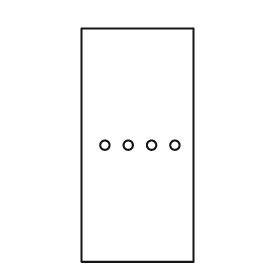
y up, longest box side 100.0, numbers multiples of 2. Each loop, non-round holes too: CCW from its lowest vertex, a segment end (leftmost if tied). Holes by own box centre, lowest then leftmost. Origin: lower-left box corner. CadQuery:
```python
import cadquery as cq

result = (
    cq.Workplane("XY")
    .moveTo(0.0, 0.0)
    .lineTo(48.0, 0.0)
    .lineTo(48.0, 100.0)
    .lineTo(0.0, 100.0)
    .close()
    .moveTo(10.0, 50.0)
    .circle(2.0)
    .moveTo(20.0, 50.0)
    .circle(2.0)
    .moveTo(30.0, 50.0)
    .circle(2.0)
    .moveTo(40.0, 50.0)
    .circle(2.0)
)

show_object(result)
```